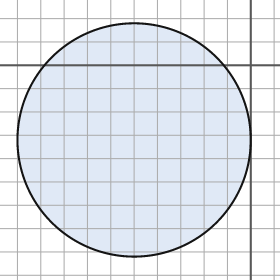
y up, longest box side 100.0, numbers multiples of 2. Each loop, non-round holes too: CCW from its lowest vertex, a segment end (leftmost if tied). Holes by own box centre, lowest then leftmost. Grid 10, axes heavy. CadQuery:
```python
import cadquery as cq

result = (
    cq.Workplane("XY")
    .moveTo(-50.0, -32.0)
    .circle(50.0)
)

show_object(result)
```